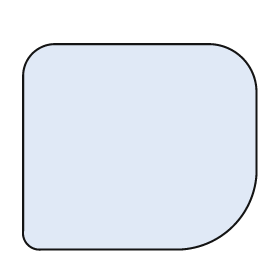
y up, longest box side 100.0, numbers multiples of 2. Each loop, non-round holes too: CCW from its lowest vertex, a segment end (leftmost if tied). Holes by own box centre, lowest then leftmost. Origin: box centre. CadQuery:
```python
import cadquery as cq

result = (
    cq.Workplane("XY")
    .moveTo(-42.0, -44.0)
    .lineTo(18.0, -44.0)
    .threePointArc((40.0, -34.0), (50.0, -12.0))
    .lineTo(50.0, 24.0)
    .threePointArc((44.0, 38.0), (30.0, 44.0))
    .lineTo(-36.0, 44.0)
    .threePointArc((-46.0, 40.0), (-50.0, 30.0))
    .lineTo(-50.0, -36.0)
    .threePointArc((-48.0, -42.0), (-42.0, -44.0))
    .close()
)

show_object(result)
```